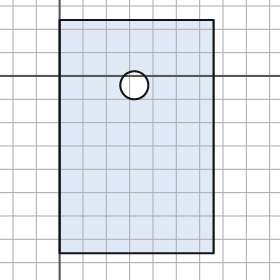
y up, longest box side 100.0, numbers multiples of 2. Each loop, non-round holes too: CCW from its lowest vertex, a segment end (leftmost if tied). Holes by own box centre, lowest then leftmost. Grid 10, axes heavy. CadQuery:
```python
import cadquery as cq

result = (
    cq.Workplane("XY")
    .moveTo(0.0, -76.0)
    .lineTo(66.0, -76.0)
    .lineTo(66.0, 24.0)
    .lineTo(0.0, 24.0)
    .close()
    .moveTo(32.0, -4.0)
    .circle(6.0)
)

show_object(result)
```